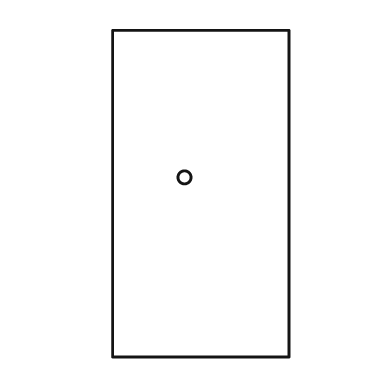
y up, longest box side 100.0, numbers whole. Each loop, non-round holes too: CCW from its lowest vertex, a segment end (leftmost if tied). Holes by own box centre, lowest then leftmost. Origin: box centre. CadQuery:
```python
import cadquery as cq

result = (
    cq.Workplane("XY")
    .moveTo(-27.0, -50.0)
    .lineTo(27.0, -50.0)
    .lineTo(27.0, 50.0)
    .lineTo(-27.0, 50.0)
    .close()
    .moveTo(-5.0, 5.0)
    .circle(2.0)
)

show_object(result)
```